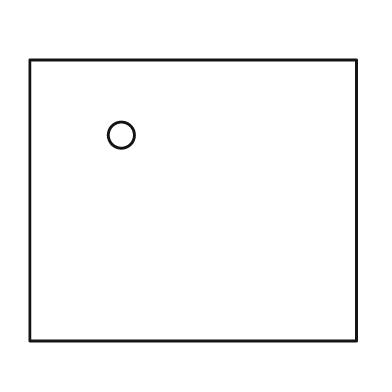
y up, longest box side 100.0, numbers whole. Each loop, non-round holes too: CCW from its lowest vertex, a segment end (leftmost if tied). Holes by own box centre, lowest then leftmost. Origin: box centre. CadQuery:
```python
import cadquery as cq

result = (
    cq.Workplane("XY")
    .moveTo(-50.0, -43.0)
    .lineTo(50.0, -43.0)
    .lineTo(50.0, 43.0)
    .lineTo(-50.0, 43.0)
    .close()
    .moveTo(-22.0, 20.0)
    .circle(4.0)
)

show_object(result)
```